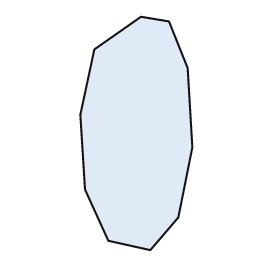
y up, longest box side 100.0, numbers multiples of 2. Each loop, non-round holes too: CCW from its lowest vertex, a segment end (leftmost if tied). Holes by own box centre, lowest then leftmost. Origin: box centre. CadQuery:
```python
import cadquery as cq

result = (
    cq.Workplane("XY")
    .moveTo(6.0, -50.0)
    .lineTo(18.0, -36.0)
    .lineTo(24.0, -6.0)
    .lineTo(22.0, 28.0)
    .lineTo(14.0, 48.0)
    .lineTo(2.0, 50.0)
    .lineTo(-18.0, 36.0)
    .lineTo(-24.0, 8.0)
    .lineTo(-22.0, -24.0)
    .lineTo(-12.0, -46.0)
    .close()
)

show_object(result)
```